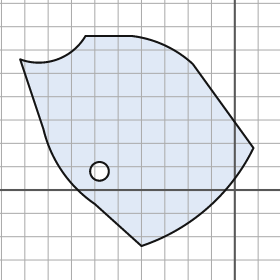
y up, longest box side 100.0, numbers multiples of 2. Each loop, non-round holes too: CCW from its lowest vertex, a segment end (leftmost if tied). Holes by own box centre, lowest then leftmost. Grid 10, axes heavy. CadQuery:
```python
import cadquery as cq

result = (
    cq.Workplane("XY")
    .moveTo(-40.0, -24.0)
    .threePointArc((-12.0, -8.0), (8.0, 18.0))
    .lineTo(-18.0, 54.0)
    .threePointArc((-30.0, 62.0), (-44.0, 66.0))
    .lineTo(-64.0, 66.0)
    .threePointArc((-76.0, 56.0), (-92.0, 56.0))
    .lineTo(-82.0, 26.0)
    .threePointArc((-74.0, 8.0), (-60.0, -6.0))
    .close()
    .moveTo(-58.0, 8.0)
    .circle(4.0)
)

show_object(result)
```